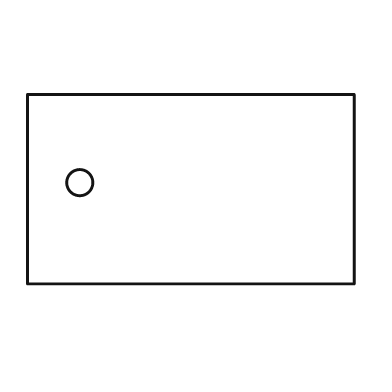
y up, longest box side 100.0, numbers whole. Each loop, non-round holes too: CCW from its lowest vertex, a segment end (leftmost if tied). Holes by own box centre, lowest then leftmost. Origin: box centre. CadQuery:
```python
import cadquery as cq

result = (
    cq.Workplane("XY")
    .moveTo(-50.0, -29.0)
    .lineTo(50.0, -29.0)
    .lineTo(50.0, 29.0)
    .lineTo(-50.0, 29.0)
    .close()
    .moveTo(-34.0, 2.0)
    .circle(4.0)
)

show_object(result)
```